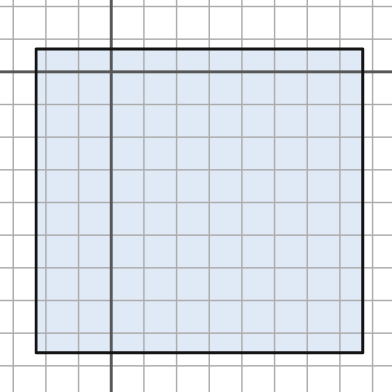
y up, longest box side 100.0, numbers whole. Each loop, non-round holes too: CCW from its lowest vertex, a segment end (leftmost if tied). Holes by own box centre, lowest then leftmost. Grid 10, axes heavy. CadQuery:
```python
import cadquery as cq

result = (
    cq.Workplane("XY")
    .moveTo(-23.0, -86.0)
    .lineTo(77.0, -86.0)
    .lineTo(77.0, 7.0)
    .lineTo(-23.0, 7.0)
    .close()
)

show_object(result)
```